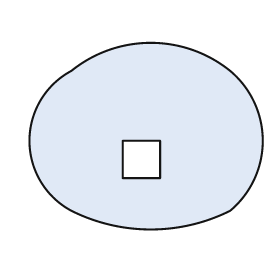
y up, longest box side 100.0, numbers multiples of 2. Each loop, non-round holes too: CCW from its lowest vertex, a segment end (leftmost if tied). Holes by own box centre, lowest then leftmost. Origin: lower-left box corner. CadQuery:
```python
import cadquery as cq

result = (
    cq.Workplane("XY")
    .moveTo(18.0, 8.0)
    .threePointArc((52.0, 0.0), (86.0, 8.0))
    .threePointArc((100.0, 38.0), (86.0, 68.0))
    .threePointArc((52.0, 80.0), (18.0, 68.0))
    .threePointArc((0.0, 38.0), (18.0, 8.0))
    .close()
    .moveTo(40.0, 22.0)
    .lineTo(56.0, 22.0)
    .lineTo(56.0, 38.0)
    .lineTo(40.0, 38.0)
    .close()
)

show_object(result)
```